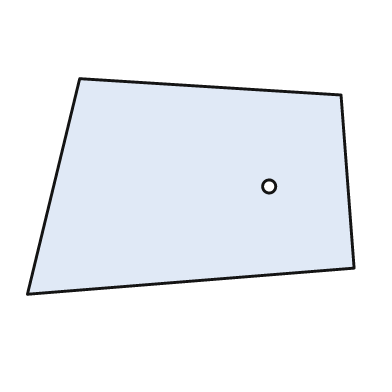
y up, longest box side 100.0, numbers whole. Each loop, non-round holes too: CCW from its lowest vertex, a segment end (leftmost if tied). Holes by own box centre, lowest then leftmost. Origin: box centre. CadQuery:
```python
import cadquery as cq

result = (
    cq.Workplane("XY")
    .moveTo(-50.0, -33.0)
    .lineTo(50.0, -25.0)
    .lineTo(46.0, 28.0)
    .lineTo(-34.0, 33.0)
    .close()
    .moveTo(24.0, 0.0)
    .circle(2.0)
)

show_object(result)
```